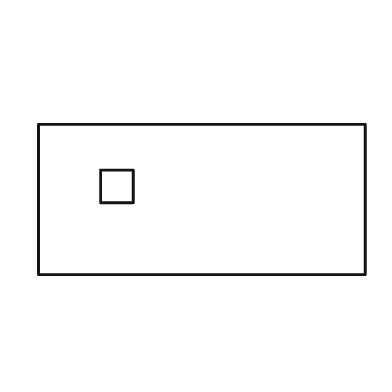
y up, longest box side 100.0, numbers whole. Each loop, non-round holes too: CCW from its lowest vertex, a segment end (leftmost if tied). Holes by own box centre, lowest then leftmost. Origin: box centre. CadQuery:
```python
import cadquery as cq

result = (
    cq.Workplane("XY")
    .moveTo(-50.0, -23.0)
    .lineTo(50.0, -23.0)
    .lineTo(50.0, 23.0)
    .lineTo(-50.0, 23.0)
    .close()
    .moveTo(-31.0, -1.0)
    .lineTo(-21.0, -1.0)
    .lineTo(-21.0, 9.0)
    .lineTo(-31.0, 9.0)
    .close()
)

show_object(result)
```